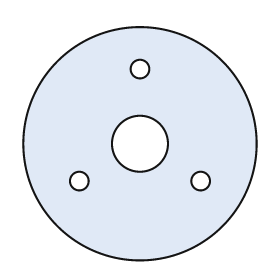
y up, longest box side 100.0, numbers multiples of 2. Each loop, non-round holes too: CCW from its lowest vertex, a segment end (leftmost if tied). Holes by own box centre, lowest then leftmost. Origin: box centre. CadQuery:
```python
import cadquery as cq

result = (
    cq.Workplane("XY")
    .moveTo(0.0, 0.0)
    .circle(50.0)
    .moveTo(-26.0, -16.0)
    .circle(4.0)
    .moveTo(26.0, -16.0)
    .circle(4.0)
    .moveTo(0.0, 0.0)
    .circle(12.0)
    .moveTo(0.0, 32.0)
    .circle(4.0)
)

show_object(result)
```